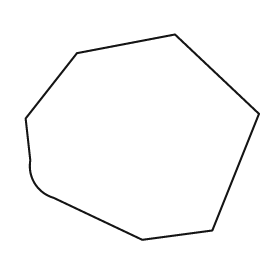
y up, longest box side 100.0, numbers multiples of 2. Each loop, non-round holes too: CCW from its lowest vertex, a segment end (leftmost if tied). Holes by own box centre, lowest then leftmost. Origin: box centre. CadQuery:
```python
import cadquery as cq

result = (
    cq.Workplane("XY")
    .moveTo(0.0, -44.0)
    .lineTo(30.0, -40.0)
    .lineTo(50.0, 10.0)
    .lineTo(14.0, 44.0)
    .lineTo(-28.0, 36.0)
    .lineTo(-50.0, 8.0)
    .lineTo(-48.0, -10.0)
    .threePointArc((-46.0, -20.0), (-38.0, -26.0))
    .close()
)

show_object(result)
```